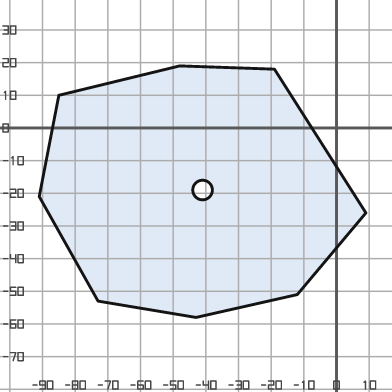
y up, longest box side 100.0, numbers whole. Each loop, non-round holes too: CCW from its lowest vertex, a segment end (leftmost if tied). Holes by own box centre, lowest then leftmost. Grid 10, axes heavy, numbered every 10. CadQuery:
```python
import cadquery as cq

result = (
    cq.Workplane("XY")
    .moveTo(-43.0, -58.0)
    .lineTo(-12.0, -51.0)
    .lineTo(9.0, -26.0)
    .lineTo(-19.0, 18.0)
    .lineTo(-48.0, 19.0)
    .lineTo(-85.0, 10.0)
    .lineTo(-91.0, -21.0)
    .lineTo(-73.0, -53.0)
    .close()
    .moveTo(-41.0, -19.0)
    .circle(3.0)
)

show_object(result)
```